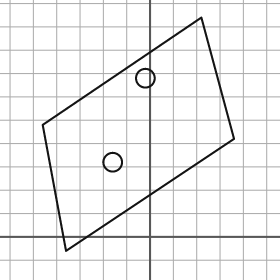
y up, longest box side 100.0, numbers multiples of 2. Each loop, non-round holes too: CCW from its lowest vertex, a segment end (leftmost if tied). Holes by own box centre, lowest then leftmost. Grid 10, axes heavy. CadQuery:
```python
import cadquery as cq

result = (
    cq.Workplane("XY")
    .moveTo(-36.0, -6.0)
    .lineTo(36.0, 42.0)
    .lineTo(22.0, 94.0)
    .lineTo(-46.0, 48.0)
    .close()
    .moveTo(-16.0, 32.0)
    .circle(4.0)
    .moveTo(-2.0, 68.0)
    .circle(4.0)
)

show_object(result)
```